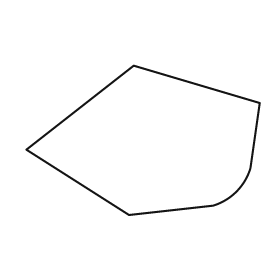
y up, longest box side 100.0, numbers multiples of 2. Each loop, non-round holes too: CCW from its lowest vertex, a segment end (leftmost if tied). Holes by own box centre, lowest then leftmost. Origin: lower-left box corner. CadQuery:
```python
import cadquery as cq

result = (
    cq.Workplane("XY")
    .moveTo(44.0, 0.0)
    .lineTo(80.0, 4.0)
    .threePointArc((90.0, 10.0), (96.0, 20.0))
    .lineTo(100.0, 48.0)
    .lineTo(46.0, 64.0)
    .lineTo(0.0, 28.0)
    .close()
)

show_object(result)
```